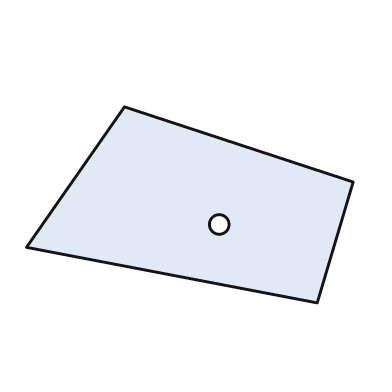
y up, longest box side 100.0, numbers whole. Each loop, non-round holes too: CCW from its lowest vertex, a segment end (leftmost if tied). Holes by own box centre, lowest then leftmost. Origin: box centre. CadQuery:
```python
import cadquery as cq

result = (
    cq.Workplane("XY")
    .moveTo(39.0, -30.0)
    .lineTo(50.0, 7.0)
    .lineTo(-20.0, 30.0)
    .lineTo(-50.0, -13.0)
    .close()
    .moveTo(9.0, -6.0)
    .circle(3.0)
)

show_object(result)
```